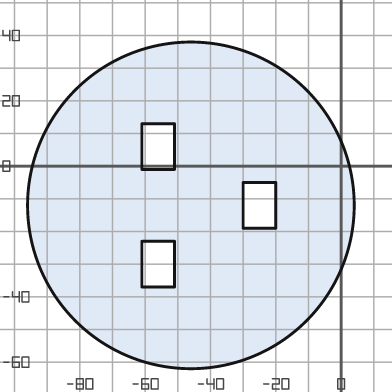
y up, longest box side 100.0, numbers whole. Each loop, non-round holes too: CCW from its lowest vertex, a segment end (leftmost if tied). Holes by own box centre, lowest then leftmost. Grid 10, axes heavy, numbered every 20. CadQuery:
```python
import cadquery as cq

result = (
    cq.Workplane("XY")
    .moveTo(-46.0, -12.0)
    .circle(50.0)
    .moveTo(-61.0, -37.0)
    .lineTo(-51.0, -37.0)
    .lineTo(-51.0, -23.0)
    .lineTo(-61.0, -23.0)
    .close()
    .moveTo(-30.0, -19.0)
    .lineTo(-20.0, -19.0)
    .lineTo(-20.0, -5.0)
    .lineTo(-30.0, -5.0)
    .close()
    .moveTo(-61.0, -1.0)
    .lineTo(-51.0, -1.0)
    .lineTo(-51.0, 13.0)
    .lineTo(-61.0, 13.0)
    .close()
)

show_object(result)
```